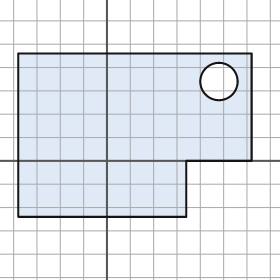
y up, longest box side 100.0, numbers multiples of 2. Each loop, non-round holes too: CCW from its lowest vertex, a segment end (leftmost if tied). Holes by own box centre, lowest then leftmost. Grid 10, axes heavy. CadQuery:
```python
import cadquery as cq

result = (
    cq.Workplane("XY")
    .moveTo(-38.0, -24.0)
    .lineTo(34.0, -24.0)
    .lineTo(34.0, 0.0)
    .lineTo(62.0, 0.0)
    .lineTo(62.0, 46.0)
    .lineTo(-38.0, 46.0)
    .close()
    .moveTo(48.0, 34.0)
    .circle(8.0)
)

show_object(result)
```